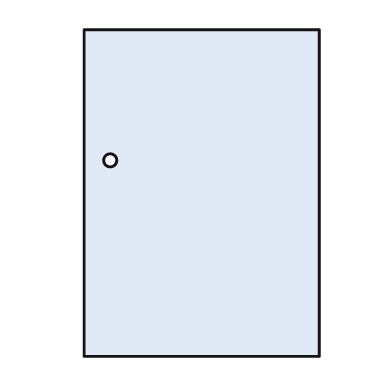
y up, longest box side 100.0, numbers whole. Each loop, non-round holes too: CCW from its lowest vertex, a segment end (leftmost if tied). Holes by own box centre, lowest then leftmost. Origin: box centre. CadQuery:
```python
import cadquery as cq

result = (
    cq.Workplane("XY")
    .moveTo(-36.0, -50.0)
    .lineTo(36.0, -50.0)
    .lineTo(36.0, 50.0)
    .lineTo(-36.0, 50.0)
    .close()
    .moveTo(-28.0, 10.0)
    .circle(2.0)
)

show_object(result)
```